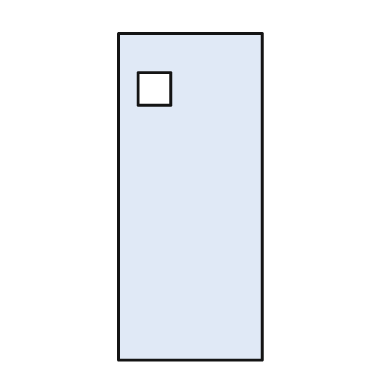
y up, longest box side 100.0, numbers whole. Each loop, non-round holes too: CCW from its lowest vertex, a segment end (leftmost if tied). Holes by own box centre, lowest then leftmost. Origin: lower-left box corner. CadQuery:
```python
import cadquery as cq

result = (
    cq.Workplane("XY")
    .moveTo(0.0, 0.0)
    .lineTo(44.0, 0.0)
    .lineTo(44.0, 100.0)
    .lineTo(0.0, 100.0)
    .close()
    .moveTo(6.0, 78.0)
    .lineTo(16.0, 78.0)
    .lineTo(16.0, 88.0)
    .lineTo(6.0, 88.0)
    .close()
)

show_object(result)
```